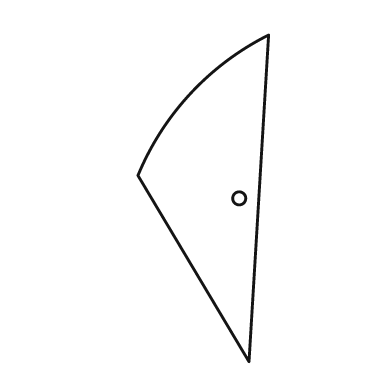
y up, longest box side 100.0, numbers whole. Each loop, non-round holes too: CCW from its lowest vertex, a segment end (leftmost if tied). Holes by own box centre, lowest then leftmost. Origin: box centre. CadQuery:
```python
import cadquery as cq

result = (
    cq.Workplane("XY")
    .moveTo(14.0, -50.0)
    .lineTo(20.0, 50.0)
    .threePointArc((-4.0, 32.0), (-20.0, 7.0))
    .close()
    .moveTo(11.0, 0.0)
    .circle(2.0)
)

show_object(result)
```